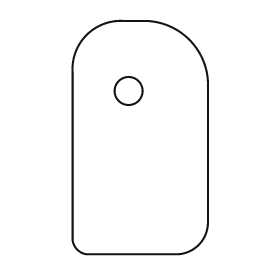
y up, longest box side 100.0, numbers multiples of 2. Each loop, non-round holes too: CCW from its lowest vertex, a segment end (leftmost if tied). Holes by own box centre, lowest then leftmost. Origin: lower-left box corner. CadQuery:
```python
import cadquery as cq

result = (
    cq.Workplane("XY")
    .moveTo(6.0, 0.0)
    .lineTo(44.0, 0.0)
    .threePointArc((54.0, 4.0), (58.0, 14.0))
    .lineTo(58.0, 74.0)
    .threePointArc((50.0, 92.0), (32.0, 100.0))
    .lineTo(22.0, 100.0)
    .threePointArc((6.0, 94.0), (0.0, 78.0))
    .lineTo(0.0, 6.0)
    .threePointArc((2.0, 2.0), (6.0, 0.0))
    .close()
    .moveTo(24.0, 70.0)
    .circle(6.0)
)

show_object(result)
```